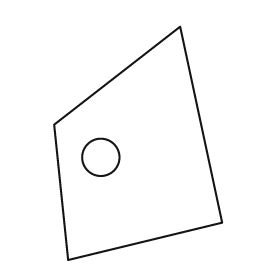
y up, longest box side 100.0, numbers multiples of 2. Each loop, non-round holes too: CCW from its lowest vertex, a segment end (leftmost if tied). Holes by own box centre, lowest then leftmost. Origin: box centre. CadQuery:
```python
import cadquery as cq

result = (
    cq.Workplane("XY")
    .moveTo(-30.0, -50.0)
    .lineTo(36.0, -34.0)
    .lineTo(18.0, 50.0)
    .lineTo(-36.0, 8.0)
    .close()
    .moveTo(-16.0, -6.0)
    .circle(8.0)
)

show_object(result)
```